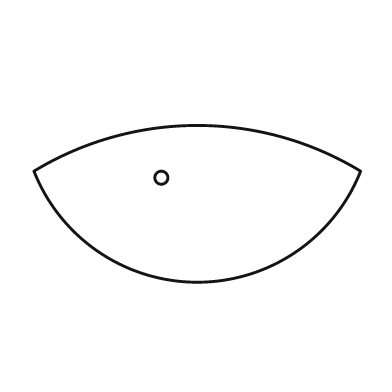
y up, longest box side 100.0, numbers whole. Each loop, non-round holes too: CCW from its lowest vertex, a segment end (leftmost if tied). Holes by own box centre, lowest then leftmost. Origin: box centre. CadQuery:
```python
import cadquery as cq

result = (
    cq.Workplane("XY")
    .moveTo(-50.0, 10.0)
    .threePointArc((0.0, -24.0), (50.0, 10.0))
    .threePointArc((0.0, 24.0), (-50.0, 10.0))
    .close()
    .moveTo(-11.0, 8.0)
    .circle(2.0)
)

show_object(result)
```